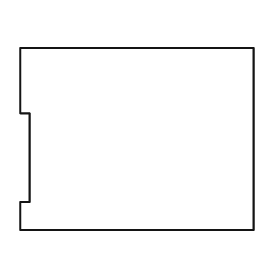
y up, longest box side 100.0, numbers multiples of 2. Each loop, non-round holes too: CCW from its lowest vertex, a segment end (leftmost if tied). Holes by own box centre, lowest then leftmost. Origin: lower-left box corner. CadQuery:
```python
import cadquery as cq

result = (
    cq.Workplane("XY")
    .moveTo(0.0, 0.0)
    .lineTo(100.0, 0.0)
    .lineTo(100.0, 78.0)
    .lineTo(0.0, 78.0)
    .lineTo(0.0, 50.0)
    .lineTo(4.0, 50.0)
    .lineTo(4.0, 12.0)
    .lineTo(0.0, 12.0)
    .close()
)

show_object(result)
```